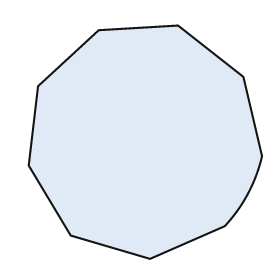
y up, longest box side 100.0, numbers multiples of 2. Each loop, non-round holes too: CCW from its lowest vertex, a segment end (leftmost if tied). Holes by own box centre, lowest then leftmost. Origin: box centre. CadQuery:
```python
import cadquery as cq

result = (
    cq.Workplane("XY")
    .moveTo(2.0, -50.0)
    .lineTo(34.0, -36.0)
    .threePointArc((44.0, -22.0), (50.0, -6.0))
    .lineTo(42.0, 28.0)
    .lineTo(14.0, 50.0)
    .lineTo(-20.0, 48.0)
    .lineTo(-46.0, 24.0)
    .lineTo(-50.0, -10.0)
    .lineTo(-32.0, -40.0)
    .close()
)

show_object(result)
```